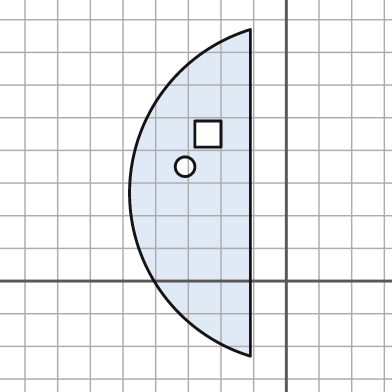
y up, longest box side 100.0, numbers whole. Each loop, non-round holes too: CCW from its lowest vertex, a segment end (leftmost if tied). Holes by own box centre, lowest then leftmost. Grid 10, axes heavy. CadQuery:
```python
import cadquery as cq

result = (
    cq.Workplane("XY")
    .moveTo(-11.0, -23.0)
    .lineTo(-11.0, 77.0)
    .threePointArc((-48.0, 27.0), (-11.0, -23.0))
    .close()
    .moveTo(-31.0, 35.0)
    .circle(3.0)
    .moveTo(-28.0, 41.0)
    .lineTo(-20.0, 41.0)
    .lineTo(-20.0, 49.0)
    .lineTo(-28.0, 49.0)
    .close()
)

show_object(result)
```